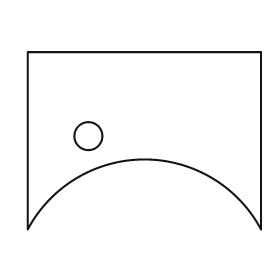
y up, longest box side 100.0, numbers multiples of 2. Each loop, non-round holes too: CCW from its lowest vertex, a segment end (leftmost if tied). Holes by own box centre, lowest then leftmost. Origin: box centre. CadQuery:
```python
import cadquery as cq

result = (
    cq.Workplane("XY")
    .moveTo(-50.0, -38.0)
    .threePointArc((0.0, -8.0), (50.0, -38.0))
    .lineTo(50.0, 38.0)
    .lineTo(-50.0, 38.0)
    .close()
    .moveTo(-24.0, 2.0)
    .circle(6.0)
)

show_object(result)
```